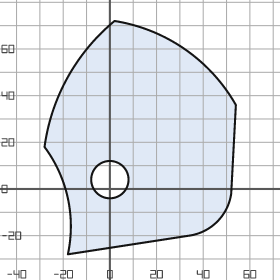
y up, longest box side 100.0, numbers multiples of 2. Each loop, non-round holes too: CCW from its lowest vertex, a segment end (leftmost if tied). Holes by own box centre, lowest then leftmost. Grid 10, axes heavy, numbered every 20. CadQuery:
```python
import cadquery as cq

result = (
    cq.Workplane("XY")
    .moveTo(-18.0, -28.0)
    .lineTo(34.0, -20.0)
    .threePointArc((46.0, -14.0), (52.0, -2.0))
    .lineTo(54.0, 36.0)
    .threePointArc((32.0, 60.0), (2.0, 72.0))
    .threePointArc((-18.0, 48.0), (-28.0, 18.0))
    .threePointArc((-18.0, -4.0), (-18.0, -28.0))
    .close()
    .moveTo(0.0, 4.0)
    .circle(8.0)
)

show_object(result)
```